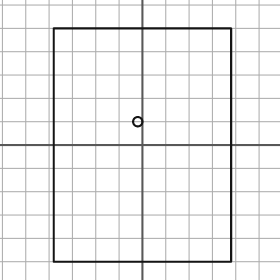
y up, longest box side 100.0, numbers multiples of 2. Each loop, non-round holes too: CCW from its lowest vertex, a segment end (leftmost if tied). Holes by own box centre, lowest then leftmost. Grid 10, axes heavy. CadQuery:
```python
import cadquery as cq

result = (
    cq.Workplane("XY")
    .moveTo(-38.0, -50.0)
    .lineTo(38.0, -50.0)
    .lineTo(38.0, 50.0)
    .lineTo(-38.0, 50.0)
    .close()
    .moveTo(-2.0, 10.0)
    .circle(2.0)
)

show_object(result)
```